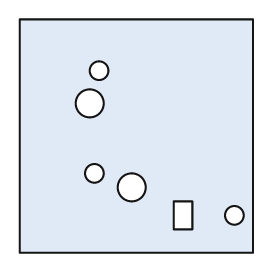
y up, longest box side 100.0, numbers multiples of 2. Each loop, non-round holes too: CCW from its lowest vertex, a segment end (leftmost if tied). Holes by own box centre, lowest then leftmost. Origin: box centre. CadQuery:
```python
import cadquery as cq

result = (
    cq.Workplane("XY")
    .moveTo(-50.0, -50.0)
    .lineTo(50.0, -50.0)
    .lineTo(50.0, 50.0)
    .lineTo(-50.0, 50.0)
    .close()
    .moveTo(16.0, -40.0)
    .lineTo(24.0, -40.0)
    .lineTo(24.0, -28.0)
    .lineTo(16.0, -28.0)
    .close()
    .moveTo(42.0, -34.0)
    .circle(4.0)
    .moveTo(-2.0, -22.0)
    .circle(6.0)
    .moveTo(-18.0, -16.0)
    .circle(4.0)
    .moveTo(-20.0, 14.0)
    .circle(6.0)
    .moveTo(-16.0, 28.0)
    .circle(4.0)
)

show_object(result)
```